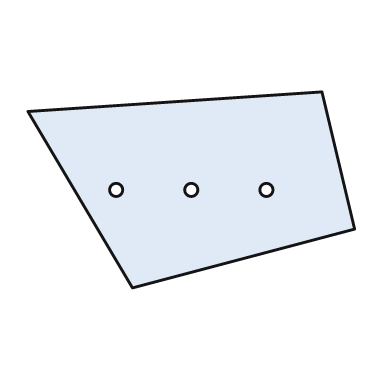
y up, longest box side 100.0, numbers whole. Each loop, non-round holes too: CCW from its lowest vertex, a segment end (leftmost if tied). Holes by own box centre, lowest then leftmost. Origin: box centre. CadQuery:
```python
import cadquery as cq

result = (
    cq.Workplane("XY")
    .moveTo(-18.0, -30.0)
    .lineTo(50.0, -12.0)
    .lineTo(40.0, 30.0)
    .lineTo(-50.0, 24.0)
    .close()
    .moveTo(-23.0, 0.0)
    .circle(2.0)
    .moveTo(0.0, 0.0)
    .circle(2.0)
    .moveTo(23.0, 0.0)
    .circle(2.0)
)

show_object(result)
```